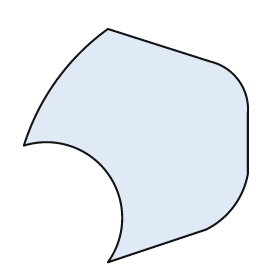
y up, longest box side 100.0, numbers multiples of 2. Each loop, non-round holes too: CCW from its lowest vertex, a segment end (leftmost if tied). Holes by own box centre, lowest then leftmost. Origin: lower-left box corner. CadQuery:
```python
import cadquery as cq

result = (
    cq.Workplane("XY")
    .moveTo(36.0, 0.0)
    .lineTo(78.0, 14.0)
    .threePointArc((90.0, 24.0), (96.0, 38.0))
    .lineTo(96.0, 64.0)
    .threePointArc((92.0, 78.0), (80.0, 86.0))
    .lineTo(36.0, 100.0)
    .threePointArc((14.0, 78.0), (0.0, 50.0))
    .threePointArc((36.0, 38.0), (36.0, 0.0))
    .close()
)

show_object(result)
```